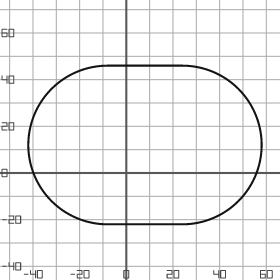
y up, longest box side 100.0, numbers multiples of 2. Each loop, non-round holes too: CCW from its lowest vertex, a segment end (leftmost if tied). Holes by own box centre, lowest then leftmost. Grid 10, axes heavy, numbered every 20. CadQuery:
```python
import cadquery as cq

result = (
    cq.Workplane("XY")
    .moveTo(-8.0, -22.0)
    .lineTo(24.0, -22.0)
    .threePointArc((58.0, 12.0), (24.0, 46.0))
    .lineTo(-8.0, 46.0)
    .threePointArc((-42.0, 12.0), (-8.0, -22.0))
    .close()
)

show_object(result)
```